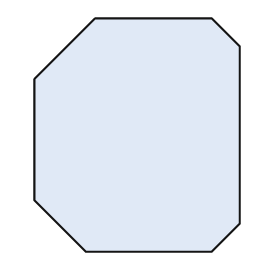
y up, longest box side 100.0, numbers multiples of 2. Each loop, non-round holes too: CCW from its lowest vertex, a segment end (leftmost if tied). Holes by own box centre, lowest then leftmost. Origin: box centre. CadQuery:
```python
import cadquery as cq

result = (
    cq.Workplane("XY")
    .moveTo(-22.0, -50.0)
    .lineTo(32.0, -50.0)
    .lineTo(44.0, -38.0)
    .lineTo(44.0, 38.0)
    .lineTo(32.0, 50.0)
    .lineTo(-18.0, 50.0)
    .lineTo(-44.0, 24.0)
    .lineTo(-44.0, -28.0)
    .close()
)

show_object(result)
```